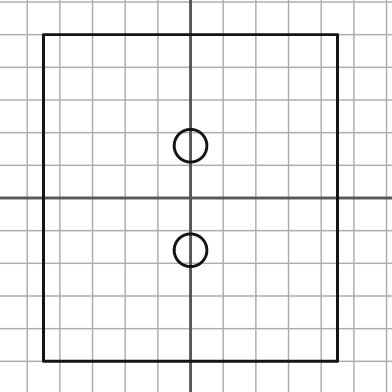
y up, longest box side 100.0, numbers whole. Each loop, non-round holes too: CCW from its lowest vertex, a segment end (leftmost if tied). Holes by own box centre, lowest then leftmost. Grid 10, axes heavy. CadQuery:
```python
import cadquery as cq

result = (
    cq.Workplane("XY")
    .moveTo(-45.0, -50.0)
    .lineTo(45.0, -50.0)
    .lineTo(45.0, 50.0)
    .lineTo(-45.0, 50.0)
    .close()
    .moveTo(0.0, -16.0)
    .circle(5.0)
    .moveTo(0.0, 16.0)
    .circle(5.0)
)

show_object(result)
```